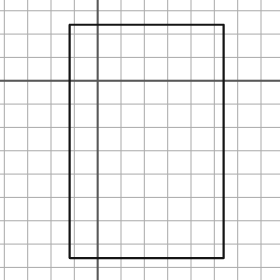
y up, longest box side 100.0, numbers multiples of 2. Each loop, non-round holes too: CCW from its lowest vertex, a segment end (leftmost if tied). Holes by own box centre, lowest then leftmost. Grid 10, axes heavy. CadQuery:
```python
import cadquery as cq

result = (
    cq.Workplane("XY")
    .moveTo(-12.0, -76.0)
    .lineTo(54.0, -76.0)
    .lineTo(54.0, 24.0)
    .lineTo(-12.0, 24.0)
    .close()
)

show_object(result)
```